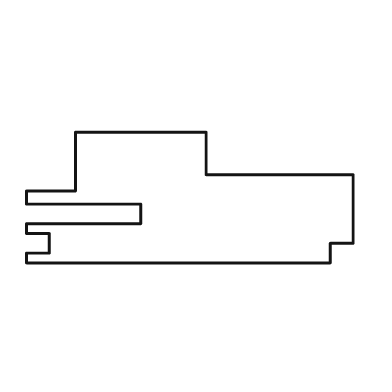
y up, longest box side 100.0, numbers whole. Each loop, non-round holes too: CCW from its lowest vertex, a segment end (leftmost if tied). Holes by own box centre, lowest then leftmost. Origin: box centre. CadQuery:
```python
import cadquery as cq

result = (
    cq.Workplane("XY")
    .moveTo(-50.0, -20.0)
    .lineTo(43.0, -20.0)
    .lineTo(43.0, -14.0)
    .lineTo(50.0, -14.0)
    .lineTo(50.0, 7.0)
    .lineTo(5.0, 7.0)
    .lineTo(5.0, 20.0)
    .lineTo(-35.0, 20.0)
    .lineTo(-35.0, 2.0)
    .lineTo(-50.0, 2.0)
    .lineTo(-50.0, -2.0)
    .lineTo(-15.0, -2.0)
    .lineTo(-15.0, -8.0)
    .lineTo(-50.0, -8.0)
    .lineTo(-50.0, -11.0)
    .lineTo(-43.0, -11.0)
    .lineTo(-43.0, -17.0)
    .lineTo(-50.0, -17.0)
    .close()
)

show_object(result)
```